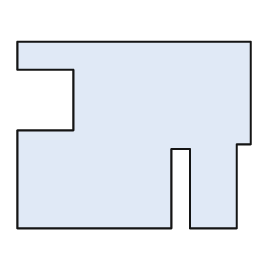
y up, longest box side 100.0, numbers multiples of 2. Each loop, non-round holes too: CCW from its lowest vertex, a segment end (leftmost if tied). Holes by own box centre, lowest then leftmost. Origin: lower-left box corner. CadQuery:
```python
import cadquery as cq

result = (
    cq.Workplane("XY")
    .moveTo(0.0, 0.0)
    .lineTo(66.0, 0.0)
    .lineTo(66.0, 34.0)
    .lineTo(74.0, 34.0)
    .lineTo(74.0, 0.0)
    .lineTo(94.0, 0.0)
    .lineTo(94.0, 36.0)
    .lineTo(100.0, 36.0)
    .lineTo(100.0, 80.0)
    .lineTo(0.0, 80.0)
    .lineTo(0.0, 68.0)
    .lineTo(24.0, 68.0)
    .lineTo(24.0, 42.0)
    .lineTo(0.0, 42.0)
    .close()
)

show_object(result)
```